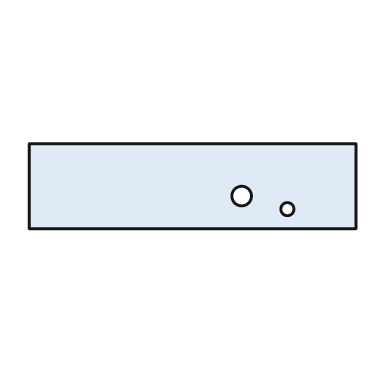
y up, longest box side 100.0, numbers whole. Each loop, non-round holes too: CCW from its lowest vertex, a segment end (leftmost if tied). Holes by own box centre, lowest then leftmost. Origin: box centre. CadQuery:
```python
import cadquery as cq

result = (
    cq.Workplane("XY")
    .moveTo(-50.0, -13.0)
    .lineTo(50.0, -13.0)
    .lineTo(50.0, 13.0)
    .lineTo(-50.0, 13.0)
    .close()
    .moveTo(29.0, -7.0)
    .circle(2.0)
    .moveTo(15.0, -3.0)
    .circle(3.0)
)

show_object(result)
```